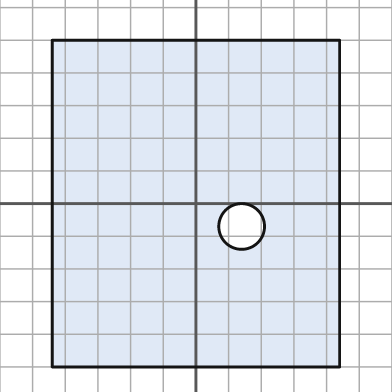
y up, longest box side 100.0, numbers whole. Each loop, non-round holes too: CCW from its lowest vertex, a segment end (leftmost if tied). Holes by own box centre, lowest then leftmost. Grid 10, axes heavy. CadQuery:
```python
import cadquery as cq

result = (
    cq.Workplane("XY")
    .moveTo(-44.0, -50.0)
    .lineTo(44.0, -50.0)
    .lineTo(44.0, 50.0)
    .lineTo(-44.0, 50.0)
    .close()
    .moveTo(14.0, -7.0)
    .circle(7.0)
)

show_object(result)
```